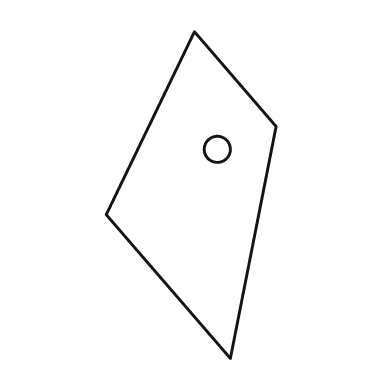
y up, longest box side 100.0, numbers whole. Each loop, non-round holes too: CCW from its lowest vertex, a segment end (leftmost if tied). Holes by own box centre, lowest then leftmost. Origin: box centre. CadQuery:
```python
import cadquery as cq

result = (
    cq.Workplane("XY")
    .moveTo(12.0, -50.0)
    .lineTo(26.0, 21.0)
    .lineTo(1.0, 50.0)
    .lineTo(-26.0, -6.0)
    .close()
    .moveTo(8.0, 14.0)
    .circle(4.0)
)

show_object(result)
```